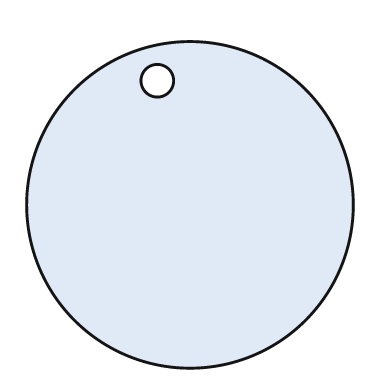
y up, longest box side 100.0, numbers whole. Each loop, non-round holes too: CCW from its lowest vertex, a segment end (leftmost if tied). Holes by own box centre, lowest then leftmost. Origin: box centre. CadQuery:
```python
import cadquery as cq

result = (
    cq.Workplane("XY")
    .moveTo(0.0, 0.0)
    .circle(50.0)
    .moveTo(-10.0, 38.0)
    .circle(5.0)
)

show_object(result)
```